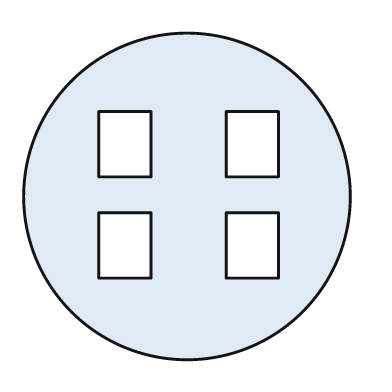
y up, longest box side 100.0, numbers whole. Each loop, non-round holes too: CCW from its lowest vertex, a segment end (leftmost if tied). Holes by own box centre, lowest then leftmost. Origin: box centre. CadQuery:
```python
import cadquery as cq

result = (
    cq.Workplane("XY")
    .moveTo(0.0, 0.0)
    .circle(50.0)
    .moveTo(-27.0, -25.0)
    .lineTo(-11.0, -25.0)
    .lineTo(-11.0, -5.0)
    .lineTo(-27.0, -5.0)
    .close()
    .moveTo(12.0, -25.0)
    .lineTo(28.0, -25.0)
    .lineTo(28.0, -5.0)
    .lineTo(12.0, -5.0)
    .close()
    .moveTo(-27.0, 6.0)
    .lineTo(-11.0, 6.0)
    .lineTo(-11.0, 26.0)
    .lineTo(-27.0, 26.0)
    .close()
    .moveTo(12.0, 6.0)
    .lineTo(28.0, 6.0)
    .lineTo(28.0, 26.0)
    .lineTo(12.0, 26.0)
    .close()
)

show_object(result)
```